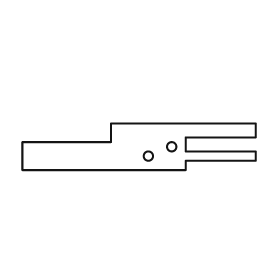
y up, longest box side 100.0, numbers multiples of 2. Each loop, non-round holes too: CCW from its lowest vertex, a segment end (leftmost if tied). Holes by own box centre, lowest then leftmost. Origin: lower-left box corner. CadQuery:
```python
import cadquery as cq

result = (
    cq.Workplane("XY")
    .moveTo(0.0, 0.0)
    .lineTo(70.0, 0.0)
    .lineTo(70.0, 4.0)
    .lineTo(100.0, 4.0)
    .lineTo(100.0, 8.0)
    .lineTo(70.0, 8.0)
    .lineTo(70.0, 14.0)
    .lineTo(100.0, 14.0)
    .lineTo(100.0, 20.0)
    .lineTo(38.0, 20.0)
    .lineTo(38.0, 12.0)
    .lineTo(0.0, 12.0)
    .close()
    .moveTo(54.0, 6.0)
    .circle(2.0)
    .moveTo(64.0, 10.0)
    .circle(2.0)
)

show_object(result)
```